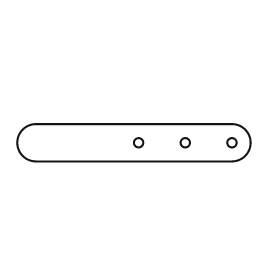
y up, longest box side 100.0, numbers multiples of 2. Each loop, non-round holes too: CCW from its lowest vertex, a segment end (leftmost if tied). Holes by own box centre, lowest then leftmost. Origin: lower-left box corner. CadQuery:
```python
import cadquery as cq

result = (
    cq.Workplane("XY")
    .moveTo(8.0, 0.0)
    .lineTo(92.0, 0.0)
    .threePointArc((100.0, 8.0), (92.0, 16.0))
    .lineTo(8.0, 16.0)
    .threePointArc((0.0, 8.0), (8.0, 0.0))
    .close()
    .moveTo(52.0, 8.0)
    .circle(2.0)
    .moveTo(72.0, 8.0)
    .circle(2.0)
    .moveTo(92.0, 8.0)
    .circle(2.0)
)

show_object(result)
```